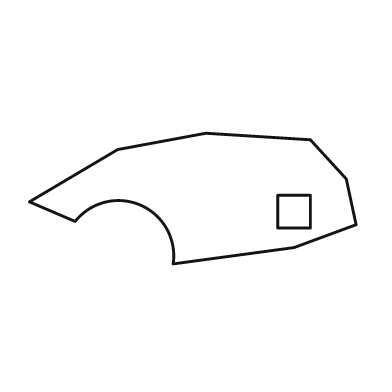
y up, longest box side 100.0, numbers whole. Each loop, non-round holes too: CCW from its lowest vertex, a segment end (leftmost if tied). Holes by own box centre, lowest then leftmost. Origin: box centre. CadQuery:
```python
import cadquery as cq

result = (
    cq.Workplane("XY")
    .moveTo(-6.0, -20.0)
    .lineTo(31.0, -15.0)
    .lineTo(50.0, -8.0)
    .lineTo(47.0, 6.0)
    .lineTo(36.0, 18.0)
    .lineTo(4.0, 20.0)
    .lineTo(-23.0, 15.0)
    .lineTo(-50.0, -1.0)
    .lineTo(-36.0, -7.0)
    .threePointArc((-16.0, -2.0), (-6.0, -20.0))
    .close()
    .moveTo(26.0, -9.0)
    .lineTo(36.0, -9.0)
    .lineTo(36.0, 1.0)
    .lineTo(26.0, 1.0)
    .close()
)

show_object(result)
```